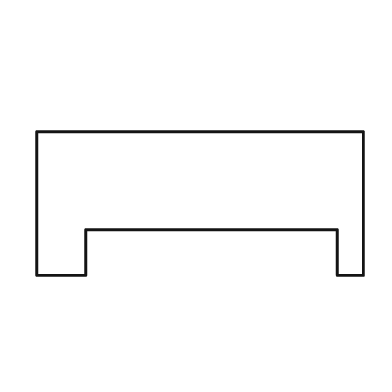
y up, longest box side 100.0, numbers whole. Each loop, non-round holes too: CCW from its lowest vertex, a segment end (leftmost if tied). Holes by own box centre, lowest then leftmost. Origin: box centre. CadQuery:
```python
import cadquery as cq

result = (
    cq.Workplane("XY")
    .moveTo(-50.0, -22.0)
    .lineTo(-35.0, -22.0)
    .lineTo(-35.0, -8.0)
    .lineTo(42.0, -8.0)
    .lineTo(42.0, -22.0)
    .lineTo(50.0, -22.0)
    .lineTo(50.0, 22.0)
    .lineTo(-50.0, 22.0)
    .close()
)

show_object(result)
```